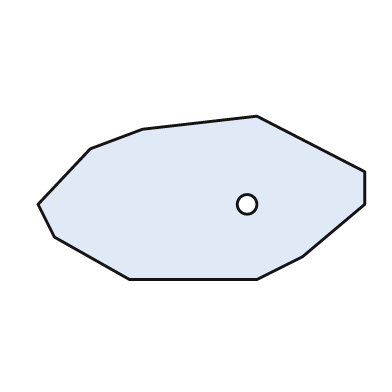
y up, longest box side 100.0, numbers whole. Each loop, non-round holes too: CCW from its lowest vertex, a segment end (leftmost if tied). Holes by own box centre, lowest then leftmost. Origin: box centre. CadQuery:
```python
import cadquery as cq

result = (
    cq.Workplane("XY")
    .moveTo(-22.0, -25.0)
    .lineTo(17.0, -25.0)
    .lineTo(31.0, -18.0)
    .lineTo(50.0, -2.0)
    .lineTo(50.0, 8.0)
    .lineTo(17.0, 25.0)
    .lineTo(-18.0, 21.0)
    .lineTo(-34.0, 15.0)
    .lineTo(-50.0, -2.0)
    .lineTo(-45.0, -12.0)
    .close()
    .moveTo(14.0, -2.0)
    .circle(3.0)
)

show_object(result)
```